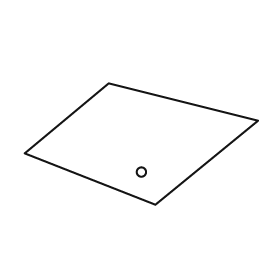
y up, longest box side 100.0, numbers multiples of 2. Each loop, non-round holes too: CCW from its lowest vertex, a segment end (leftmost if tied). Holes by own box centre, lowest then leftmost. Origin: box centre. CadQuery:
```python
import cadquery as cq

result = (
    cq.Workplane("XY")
    .moveTo(6.0, -26.0)
    .lineTo(50.0, 10.0)
    .lineTo(-14.0, 26.0)
    .lineTo(-50.0, -4.0)
    .close()
    .moveTo(0.0, -12.0)
    .circle(2.0)
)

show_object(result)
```